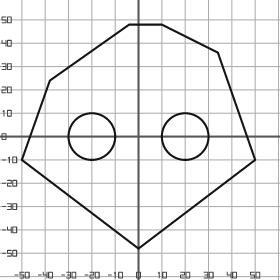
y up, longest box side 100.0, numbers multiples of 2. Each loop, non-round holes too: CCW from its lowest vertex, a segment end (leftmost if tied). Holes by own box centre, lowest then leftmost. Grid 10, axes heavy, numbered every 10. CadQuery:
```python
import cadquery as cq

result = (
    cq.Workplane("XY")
    .moveTo(0.0, -48.0)
    .lineTo(50.0, -10.0)
    .lineTo(34.0, 36.0)
    .lineTo(10.0, 48.0)
    .lineTo(-4.0, 48.0)
    .lineTo(-38.0, 24.0)
    .lineTo(-50.0, -10.0)
    .close()
    .moveTo(-20.0, 0.0)
    .circle(10.0)
    .moveTo(20.0, 0.0)
    .circle(10.0)
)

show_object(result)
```